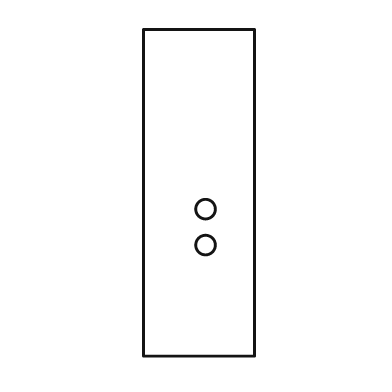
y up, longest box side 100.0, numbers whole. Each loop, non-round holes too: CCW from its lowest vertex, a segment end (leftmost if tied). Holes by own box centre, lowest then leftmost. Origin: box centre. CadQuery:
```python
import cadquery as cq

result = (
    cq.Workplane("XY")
    .moveTo(-17.0, -50.0)
    .lineTo(17.0, -50.0)
    .lineTo(17.0, 50.0)
    .lineTo(-17.0, 50.0)
    .close()
    .moveTo(2.0, -16.0)
    .circle(3.0)
    .moveTo(2.0, -5.0)
    .circle(3.0)
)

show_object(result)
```